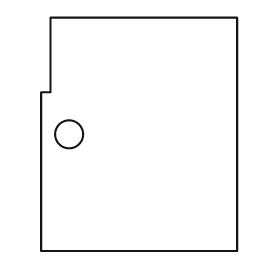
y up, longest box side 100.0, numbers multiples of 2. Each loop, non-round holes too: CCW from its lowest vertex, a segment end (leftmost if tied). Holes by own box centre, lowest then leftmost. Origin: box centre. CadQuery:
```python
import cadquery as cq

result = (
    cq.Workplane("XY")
    .moveTo(-42.0, -50.0)
    .lineTo(42.0, -50.0)
    .lineTo(42.0, 50.0)
    .lineTo(-38.0, 50.0)
    .lineTo(-38.0, 18.0)
    .lineTo(-42.0, 18.0)
    .close()
    .moveTo(-30.0, 0.0)
    .circle(6.0)
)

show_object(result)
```